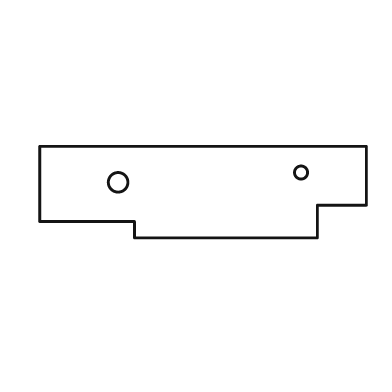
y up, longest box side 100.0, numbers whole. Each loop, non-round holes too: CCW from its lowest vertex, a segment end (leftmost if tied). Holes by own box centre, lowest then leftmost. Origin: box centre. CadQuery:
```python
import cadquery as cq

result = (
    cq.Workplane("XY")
    .moveTo(-21.0, -14.0)
    .lineTo(35.0, -14.0)
    .lineTo(35.0, -4.0)
    .lineTo(50.0, -4.0)
    .lineTo(50.0, 14.0)
    .lineTo(-50.0, 14.0)
    .lineTo(-50.0, -9.0)
    .lineTo(-21.0, -9.0)
    .close()
    .moveTo(-26.0, 3.0)
    .circle(3.0)
    .moveTo(30.0, 6.0)
    .circle(2.0)
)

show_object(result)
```